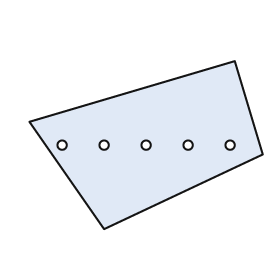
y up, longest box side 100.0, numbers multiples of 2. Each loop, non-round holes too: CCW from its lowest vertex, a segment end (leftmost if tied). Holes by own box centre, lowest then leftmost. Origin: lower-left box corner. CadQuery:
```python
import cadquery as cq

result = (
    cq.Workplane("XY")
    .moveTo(32.0, 0.0)
    .lineTo(100.0, 32.0)
    .lineTo(88.0, 72.0)
    .lineTo(0.0, 46.0)
    .close()
    .moveTo(14.0, 36.0)
    .circle(2.0)
    .moveTo(32.0, 36.0)
    .circle(2.0)
    .moveTo(50.0, 36.0)
    .circle(2.0)
    .moveTo(68.0, 36.0)
    .circle(2.0)
    .moveTo(86.0, 36.0)
    .circle(2.0)
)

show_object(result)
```